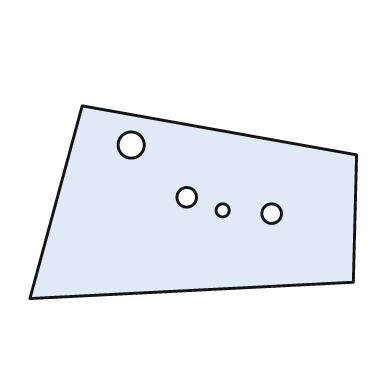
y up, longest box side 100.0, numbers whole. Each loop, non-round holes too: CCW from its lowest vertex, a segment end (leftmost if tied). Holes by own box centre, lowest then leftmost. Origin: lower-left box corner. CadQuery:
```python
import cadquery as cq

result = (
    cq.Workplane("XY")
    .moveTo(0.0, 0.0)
    .lineTo(99.0, 5.0)
    .lineTo(100.0, 44.0)
    .lineTo(16.0, 59.0)
    .close()
    .moveTo(74.0, 26.0)
    .circle(3.0)
    .moveTo(59.0, 27.0)
    .circle(2.0)
    .moveTo(48.0, 31.0)
    .circle(3.0)
    .moveTo(31.0, 47.0)
    .circle(4.0)
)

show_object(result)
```